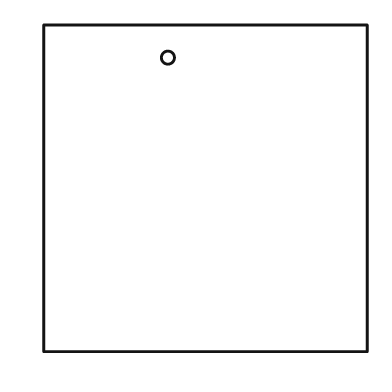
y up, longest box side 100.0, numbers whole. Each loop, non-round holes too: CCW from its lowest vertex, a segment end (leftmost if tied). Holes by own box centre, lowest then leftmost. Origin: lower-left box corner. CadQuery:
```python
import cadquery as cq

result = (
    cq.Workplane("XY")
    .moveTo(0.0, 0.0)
    .lineTo(99.0, 0.0)
    .lineTo(99.0, 100.0)
    .lineTo(0.0, 100.0)
    .close()
    .moveTo(38.0, 90.0)
    .circle(2.0)
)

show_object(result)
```